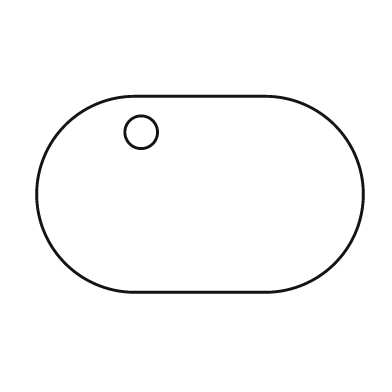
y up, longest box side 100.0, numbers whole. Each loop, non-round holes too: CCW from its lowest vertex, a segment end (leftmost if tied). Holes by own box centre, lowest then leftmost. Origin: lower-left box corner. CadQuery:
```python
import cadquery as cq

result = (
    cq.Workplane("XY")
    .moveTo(30.0, 0.0)
    .lineTo(70.0, 0.0)
    .threePointArc((100.0, 30.0), (70.0, 60.0))
    .lineTo(30.0, 60.0)
    .threePointArc((0.0, 30.0), (30.0, 0.0))
    .close()
    .moveTo(32.0, 49.0)
    .circle(5.0)
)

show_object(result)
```